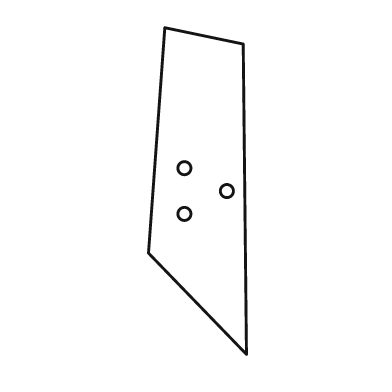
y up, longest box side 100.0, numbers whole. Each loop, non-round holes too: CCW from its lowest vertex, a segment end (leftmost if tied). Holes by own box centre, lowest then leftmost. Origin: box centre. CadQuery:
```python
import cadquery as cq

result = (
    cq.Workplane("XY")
    .moveTo(15.0, -50.0)
    .lineTo(14.0, 45.0)
    .lineTo(-10.0, 50.0)
    .lineTo(-15.0, -19.0)
    .close()
    .moveTo(-4.0, -7.0)
    .circle(2.0)
    .moveTo(9.0, 0.0)
    .circle(2.0)
    .moveTo(-4.0, 7.0)
    .circle(2.0)
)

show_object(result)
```